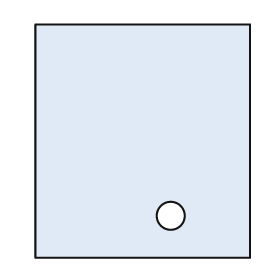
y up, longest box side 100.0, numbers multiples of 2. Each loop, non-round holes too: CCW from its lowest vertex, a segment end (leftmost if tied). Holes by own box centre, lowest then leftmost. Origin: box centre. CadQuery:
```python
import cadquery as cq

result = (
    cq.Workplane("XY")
    .moveTo(-46.0, -50.0)
    .lineTo(46.0, -50.0)
    .lineTo(46.0, 50.0)
    .lineTo(-46.0, 50.0)
    .close()
    .moveTo(12.0, -32.0)
    .circle(6.0)
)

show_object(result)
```